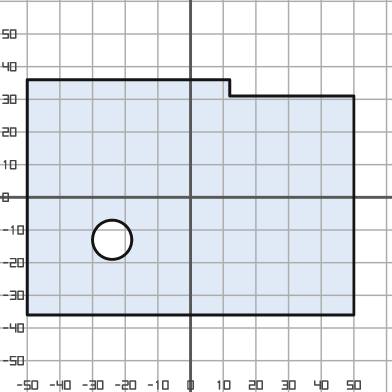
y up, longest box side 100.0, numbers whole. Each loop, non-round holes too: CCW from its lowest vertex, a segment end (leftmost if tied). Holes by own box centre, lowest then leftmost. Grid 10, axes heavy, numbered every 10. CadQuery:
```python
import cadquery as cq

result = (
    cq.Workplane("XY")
    .moveTo(-50.0, -36.0)
    .lineTo(50.0, -36.0)
    .lineTo(50.0, 31.0)
    .lineTo(12.0, 31.0)
    .lineTo(12.0, 36.0)
    .lineTo(-50.0, 36.0)
    .close()
    .moveTo(-24.0, -13.0)
    .circle(6.0)
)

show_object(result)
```